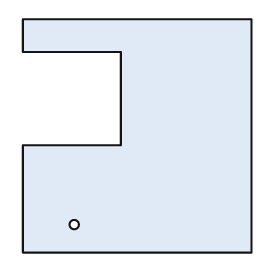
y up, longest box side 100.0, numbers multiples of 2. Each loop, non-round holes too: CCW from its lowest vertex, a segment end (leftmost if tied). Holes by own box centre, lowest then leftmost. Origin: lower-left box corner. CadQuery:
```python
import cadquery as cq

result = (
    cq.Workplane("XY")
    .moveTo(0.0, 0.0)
    .lineTo(98.0, 0.0)
    .lineTo(98.0, 100.0)
    .lineTo(0.0, 100.0)
    .lineTo(0.0, 86.0)
    .lineTo(42.0, 86.0)
    .lineTo(42.0, 46.0)
    .lineTo(0.0, 46.0)
    .close()
    .moveTo(22.0, 12.0)
    .circle(2.0)
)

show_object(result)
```